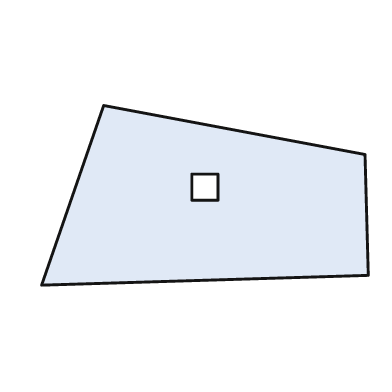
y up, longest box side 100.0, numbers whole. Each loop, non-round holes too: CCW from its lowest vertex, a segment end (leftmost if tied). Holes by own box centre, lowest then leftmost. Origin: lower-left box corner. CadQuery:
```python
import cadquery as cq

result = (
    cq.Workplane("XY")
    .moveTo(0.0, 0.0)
    .lineTo(100.0, 3.0)
    .lineTo(99.0, 40.0)
    .lineTo(19.0, 55.0)
    .close()
    .moveTo(46.0, 26.0)
    .lineTo(54.0, 26.0)
    .lineTo(54.0, 34.0)
    .lineTo(46.0, 34.0)
    .close()
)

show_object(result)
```